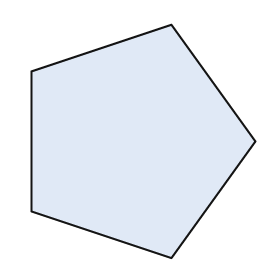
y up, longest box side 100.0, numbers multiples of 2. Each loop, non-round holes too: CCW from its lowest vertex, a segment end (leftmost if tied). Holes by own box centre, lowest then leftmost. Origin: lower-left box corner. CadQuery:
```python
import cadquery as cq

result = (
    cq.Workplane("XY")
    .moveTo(60.0, 0.0)
    .lineTo(96.0, 50.0)
    .lineTo(60.0, 100.0)
    .lineTo(0.0, 80.0)
    .lineTo(0.0, 20.0)
    .close()
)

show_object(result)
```